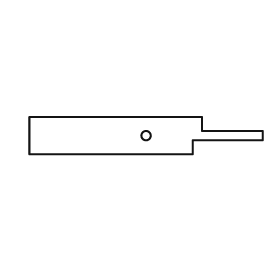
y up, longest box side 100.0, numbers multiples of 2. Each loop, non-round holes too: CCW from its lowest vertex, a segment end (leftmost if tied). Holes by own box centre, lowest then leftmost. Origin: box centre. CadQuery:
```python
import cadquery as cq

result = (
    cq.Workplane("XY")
    .moveTo(-50.0, -8.0)
    .lineTo(20.0, -8.0)
    .lineTo(20.0, -2.0)
    .lineTo(50.0, -2.0)
    .lineTo(50.0, 2.0)
    .lineTo(24.0, 2.0)
    .lineTo(24.0, 8.0)
    .lineTo(-50.0, 8.0)
    .close()
    .moveTo(0.0, 0.0)
    .circle(2.0)
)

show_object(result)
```